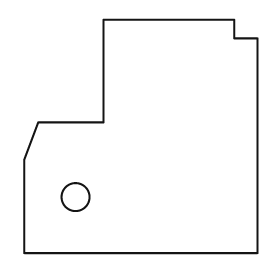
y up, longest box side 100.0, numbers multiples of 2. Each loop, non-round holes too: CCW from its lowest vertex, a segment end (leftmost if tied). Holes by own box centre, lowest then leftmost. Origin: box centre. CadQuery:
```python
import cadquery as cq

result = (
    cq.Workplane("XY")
    .moveTo(-50.0, -50.0)
    .lineTo(50.0, -50.0)
    .lineTo(50.0, 42.0)
    .lineTo(40.0, 42.0)
    .lineTo(40.0, 50.0)
    .lineTo(-16.0, 50.0)
    .lineTo(-16.0, 6.0)
    .lineTo(-44.0, 6.0)
    .lineTo(-50.0, -10.0)
    .close()
    .moveTo(-28.0, -26.0)
    .circle(6.0)
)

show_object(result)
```